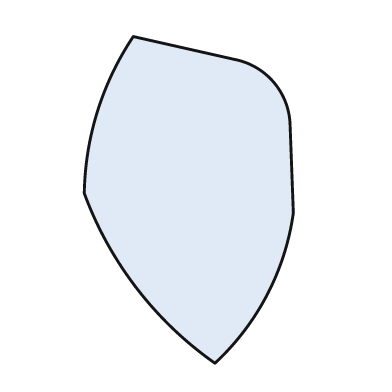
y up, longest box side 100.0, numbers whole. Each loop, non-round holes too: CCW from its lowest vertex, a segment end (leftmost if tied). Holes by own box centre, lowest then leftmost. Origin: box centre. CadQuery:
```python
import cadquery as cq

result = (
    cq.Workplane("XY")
    .moveTo(8.0, -50.0)
    .threePointArc((24.0, -29.0), (32.0, -4.0))
    .lineTo(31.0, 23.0)
    .threePointArc((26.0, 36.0), (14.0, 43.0))
    .lineTo(-17.0, 50.0)
    .threePointArc((-28.0, 27.0), (-32.0, 2.0))
    .threePointArc((-16.0, -27.0), (8.0, -50.0))
    .close()
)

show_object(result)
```